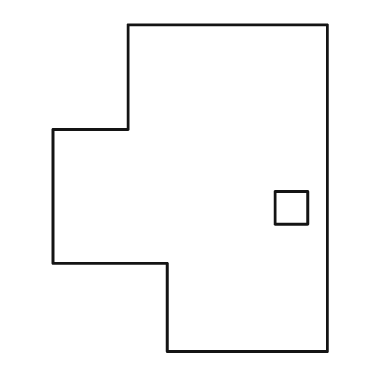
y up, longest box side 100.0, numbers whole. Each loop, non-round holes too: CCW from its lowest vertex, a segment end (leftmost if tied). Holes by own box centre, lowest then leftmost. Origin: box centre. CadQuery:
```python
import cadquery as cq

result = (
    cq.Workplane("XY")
    .moveTo(-7.0, -50.0)
    .lineTo(42.0, -50.0)
    .lineTo(42.0, 50.0)
    .lineTo(-19.0, 50.0)
    .lineTo(-19.0, 18.0)
    .lineTo(-42.0, 18.0)
    .lineTo(-42.0, -23.0)
    .lineTo(-7.0, -23.0)
    .close()
    .moveTo(26.0, -11.0)
    .lineTo(36.0, -11.0)
    .lineTo(36.0, -1.0)
    .lineTo(26.0, -1.0)
    .close()
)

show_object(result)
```